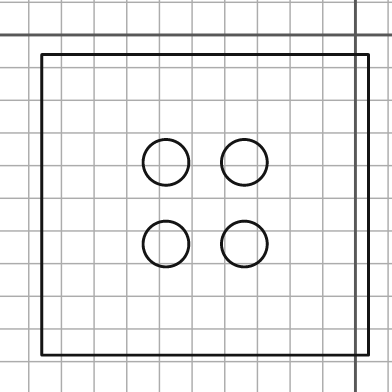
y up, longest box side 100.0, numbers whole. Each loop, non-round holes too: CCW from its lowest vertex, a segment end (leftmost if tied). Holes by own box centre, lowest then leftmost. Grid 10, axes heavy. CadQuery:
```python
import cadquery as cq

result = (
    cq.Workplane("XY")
    .moveTo(-96.0, -98.0)
    .lineTo(4.0, -98.0)
    .lineTo(4.0, -6.0)
    .lineTo(-96.0, -6.0)
    .close()
    .moveTo(-58.0, -64.0)
    .circle(7.0)
    .moveTo(-34.0, -64.0)
    .circle(7.0)
    .moveTo(-58.0, -39.0)
    .circle(7.0)
    .moveTo(-34.0, -39.0)
    .circle(7.0)
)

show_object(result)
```